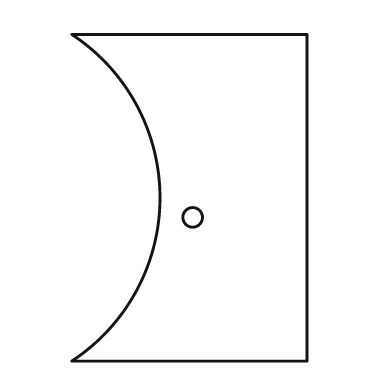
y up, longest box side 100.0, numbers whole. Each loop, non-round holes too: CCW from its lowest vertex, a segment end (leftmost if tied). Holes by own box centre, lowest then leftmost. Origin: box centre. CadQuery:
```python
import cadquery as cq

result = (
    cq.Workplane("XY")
    .moveTo(-36.0, -50.0)
    .lineTo(36.0, -50.0)
    .lineTo(36.0, 50.0)
    .lineTo(-36.0, 50.0)
    .threePointArc((-9.0, 0.0), (-36.0, -50.0))
    .close()
    .moveTo(1.0, -6.0)
    .circle(3.0)
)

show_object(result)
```